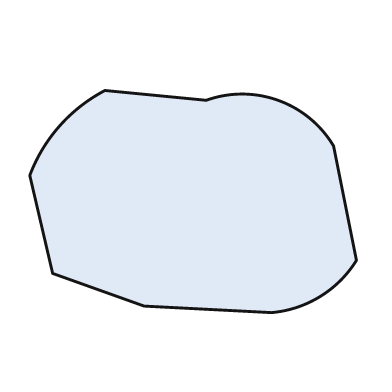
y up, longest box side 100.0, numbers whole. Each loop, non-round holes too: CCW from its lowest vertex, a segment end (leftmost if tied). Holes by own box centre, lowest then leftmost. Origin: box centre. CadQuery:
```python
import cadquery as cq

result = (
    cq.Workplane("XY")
    .moveTo(24.0, -34.0)
    .threePointArc((39.0, -29.0), (50.0, -18.0))
    .lineTo(43.0, 17.0)
    .threePointArc((26.0, 31.0), (4.0, 31.0))
    .lineTo(-27.0, 34.0)
    .threePointArc((-41.0, 23.0), (-50.0, 8.0))
    .lineTo(-43.0, -22.0)
    .lineTo(-15.0, -32.0)
    .close()
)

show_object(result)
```